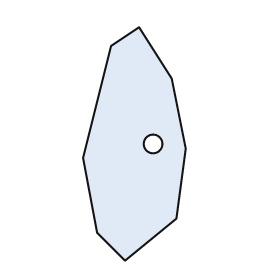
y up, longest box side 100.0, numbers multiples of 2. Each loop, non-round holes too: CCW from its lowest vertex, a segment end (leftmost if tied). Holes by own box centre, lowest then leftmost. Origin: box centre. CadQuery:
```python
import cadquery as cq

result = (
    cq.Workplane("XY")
    .moveTo(-4.0, -50.0)
    .lineTo(18.0, -32.0)
    .lineTo(22.0, -2.0)
    .lineTo(16.0, 28.0)
    .lineTo(2.0, 50.0)
    .lineTo(-10.0, 42.0)
    .lineTo(-22.0, -6.0)
    .lineTo(-16.0, -38.0)
    .close()
    .moveTo(8.0, 0.0)
    .circle(4.0)
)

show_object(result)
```